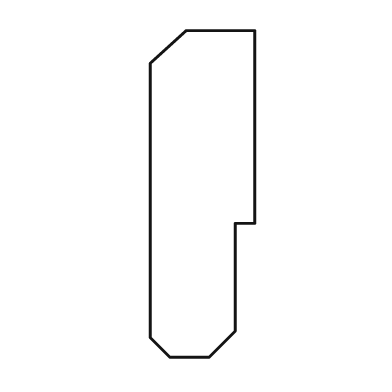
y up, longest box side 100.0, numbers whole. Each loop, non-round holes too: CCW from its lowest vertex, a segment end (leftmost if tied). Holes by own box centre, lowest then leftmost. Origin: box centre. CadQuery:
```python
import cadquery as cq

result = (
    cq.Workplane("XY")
    .moveTo(-10.0, -50.0)
    .lineTo(2.0, -50.0)
    .lineTo(10.0, -42.0)
    .lineTo(10.0, -9.0)
    .lineTo(16.0, -9.0)
    .lineTo(16.0, 50.0)
    .lineTo(-5.0, 50.0)
    .lineTo(-16.0, 40.0)
    .lineTo(-16.0, -44.0)
    .close()
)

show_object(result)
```